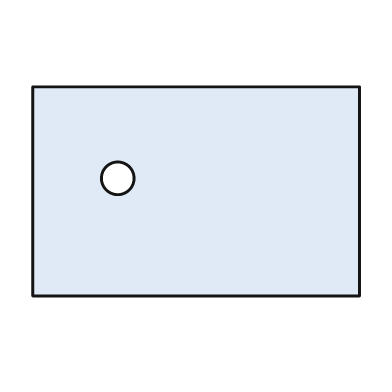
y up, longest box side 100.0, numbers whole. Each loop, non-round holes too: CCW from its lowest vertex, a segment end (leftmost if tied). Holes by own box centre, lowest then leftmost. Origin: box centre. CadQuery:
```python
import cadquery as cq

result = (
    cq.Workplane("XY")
    .moveTo(-50.0, -32.0)
    .lineTo(50.0, -32.0)
    .lineTo(50.0, 32.0)
    .lineTo(-50.0, 32.0)
    .close()
    .moveTo(-24.0, 4.0)
    .circle(5.0)
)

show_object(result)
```